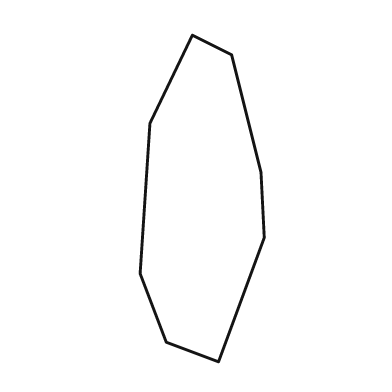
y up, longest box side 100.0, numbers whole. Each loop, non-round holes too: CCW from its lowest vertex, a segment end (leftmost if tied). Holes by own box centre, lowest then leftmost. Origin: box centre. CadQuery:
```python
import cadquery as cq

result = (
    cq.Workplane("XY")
    .moveTo(5.0, -50.0)
    .lineTo(19.0, -12.0)
    .lineTo(18.0, 8.0)
    .lineTo(9.0, 44.0)
    .lineTo(-3.0, 50.0)
    .lineTo(-16.0, 23.0)
    .lineTo(-19.0, -23.0)
    .lineTo(-11.0, -44.0)
    .close()
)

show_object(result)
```